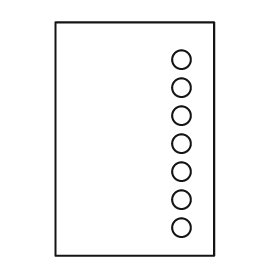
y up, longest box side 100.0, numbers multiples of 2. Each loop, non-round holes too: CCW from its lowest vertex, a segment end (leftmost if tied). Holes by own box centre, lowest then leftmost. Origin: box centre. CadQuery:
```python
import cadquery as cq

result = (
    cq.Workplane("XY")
    .moveTo(-34.0, -50.0)
    .lineTo(34.0, -50.0)
    .lineTo(34.0, 50.0)
    .lineTo(-34.0, 50.0)
    .close()
    .moveTo(20.0, -38.0)
    .circle(4.0)
    .moveTo(20.0, -26.0)
    .circle(4.0)
    .moveTo(20.0, -14.0)
    .circle(4.0)
    .moveTo(20.0, -2.0)
    .circle(4.0)
    .moveTo(20.0, 10.0)
    .circle(4.0)
    .moveTo(20.0, 22.0)
    .circle(4.0)
    .moveTo(20.0, 34.0)
    .circle(4.0)
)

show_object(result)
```